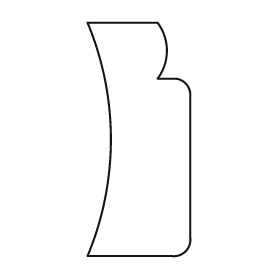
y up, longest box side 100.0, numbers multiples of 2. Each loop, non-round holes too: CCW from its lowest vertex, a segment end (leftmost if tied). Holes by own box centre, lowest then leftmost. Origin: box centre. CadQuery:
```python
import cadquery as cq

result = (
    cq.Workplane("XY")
    .moveTo(-22.0, -50.0)
    .lineTo(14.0, -50.0)
    .threePointArc((20.0, -48.0), (22.0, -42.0))
    .lineTo(22.0, 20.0)
    .threePointArc((20.0, 24.0), (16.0, 26.0))
    .lineTo(8.0, 26.0)
    .threePointArc((12.0, 38.0), (8.0, 50.0))
    .lineTo(-22.0, 50.0)
    .threePointArc((-12.0, 0.0), (-22.0, -50.0))
    .close()
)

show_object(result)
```